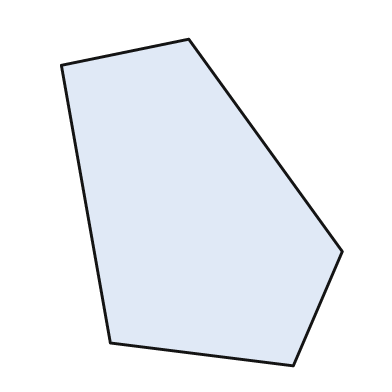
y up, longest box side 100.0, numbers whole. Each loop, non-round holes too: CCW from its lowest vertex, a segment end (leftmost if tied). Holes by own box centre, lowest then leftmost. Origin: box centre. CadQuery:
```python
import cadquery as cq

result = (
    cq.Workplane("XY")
    .moveTo(28.0, -50.0)
    .lineTo(43.0, -15.0)
    .lineTo(-4.0, 50.0)
    .lineTo(-43.0, 42.0)
    .lineTo(-28.0, -43.0)
    .close()
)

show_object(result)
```